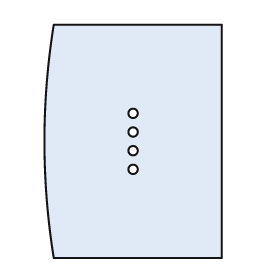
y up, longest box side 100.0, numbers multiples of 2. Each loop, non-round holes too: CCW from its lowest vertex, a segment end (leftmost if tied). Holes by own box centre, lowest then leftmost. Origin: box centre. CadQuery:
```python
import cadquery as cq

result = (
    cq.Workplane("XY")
    .moveTo(-34.0, -50.0)
    .lineTo(38.0, -50.0)
    .lineTo(38.0, 50.0)
    .lineTo(-34.0, 50.0)
    .threePointArc((-38.0, 0.0), (-34.0, -50.0))
    .close()
    .moveTo(0.0, -12.0)
    .circle(2.0)
    .moveTo(0.0, -4.0)
    .circle(2.0)
    .moveTo(0.0, 4.0)
    .circle(2.0)
    .moveTo(0.0, 12.0)
    .circle(2.0)
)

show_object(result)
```